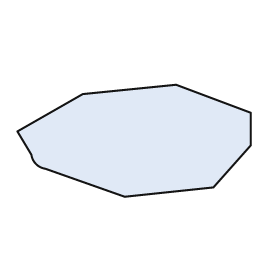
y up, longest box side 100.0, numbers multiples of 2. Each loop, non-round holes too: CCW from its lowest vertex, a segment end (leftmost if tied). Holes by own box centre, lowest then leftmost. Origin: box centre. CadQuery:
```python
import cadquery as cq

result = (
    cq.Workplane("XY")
    .moveTo(-4.0, -24.0)
    .lineTo(34.0, -20.0)
    .lineTo(50.0, -2.0)
    .lineTo(50.0, 12.0)
    .lineTo(18.0, 24.0)
    .lineTo(-22.0, 20.0)
    .lineTo(-50.0, 4.0)
    .lineTo(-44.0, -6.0)
    .threePointArc((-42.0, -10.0), (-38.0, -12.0))
    .close()
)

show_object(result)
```